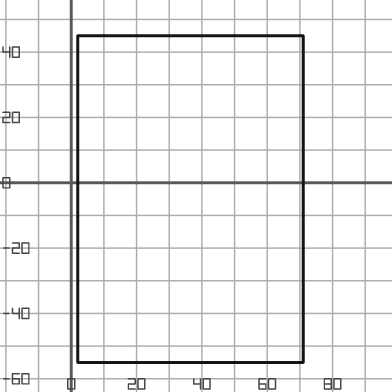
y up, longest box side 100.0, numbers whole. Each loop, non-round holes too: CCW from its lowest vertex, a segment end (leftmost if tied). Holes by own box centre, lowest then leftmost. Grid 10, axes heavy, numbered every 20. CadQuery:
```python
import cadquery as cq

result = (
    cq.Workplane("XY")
    .moveTo(2.0, -55.0)
    .lineTo(71.0, -55.0)
    .lineTo(71.0, 45.0)
    .lineTo(2.0, 45.0)
    .close()
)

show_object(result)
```